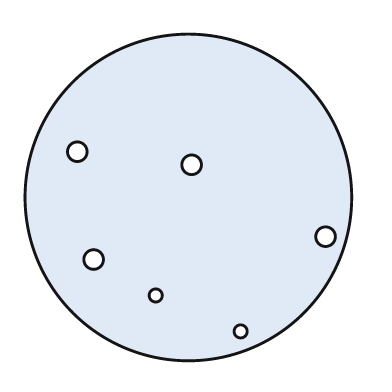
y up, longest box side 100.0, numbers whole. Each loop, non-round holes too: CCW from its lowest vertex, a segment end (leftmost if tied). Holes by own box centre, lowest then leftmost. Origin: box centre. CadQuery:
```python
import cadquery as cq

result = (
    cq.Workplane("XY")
    .moveTo(0.0, 0.0)
    .circle(50.0)
    .moveTo(16.0, -41.0)
    .circle(2.0)
    .moveTo(-10.0, -30.0)
    .circle(2.0)
    .moveTo(-29.0, -19.0)
    .circle(3.0)
    .moveTo(42.0, -12.0)
    .circle(3.0)
    .moveTo(1.0, 10.0)
    .circle(3.0)
    .moveTo(-34.0, 14.0)
    .circle(3.0)
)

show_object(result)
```